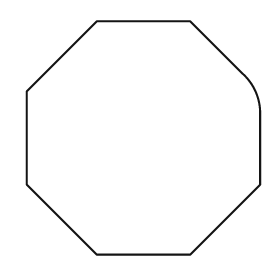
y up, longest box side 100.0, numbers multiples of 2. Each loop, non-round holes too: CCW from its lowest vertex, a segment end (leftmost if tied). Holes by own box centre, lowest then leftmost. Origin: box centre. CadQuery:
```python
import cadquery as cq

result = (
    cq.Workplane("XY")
    .moveTo(-20.0, -50.0)
    .lineTo(20.0, -50.0)
    .lineTo(50.0, -20.0)
    .lineTo(50.0, 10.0)
    .threePointArc((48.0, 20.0), (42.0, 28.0))
    .lineTo(20.0, 50.0)
    .lineTo(-20.0, 50.0)
    .lineTo(-50.0, 20.0)
    .lineTo(-50.0, -20.0)
    .close()
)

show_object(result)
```